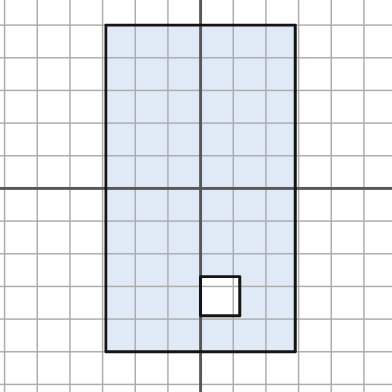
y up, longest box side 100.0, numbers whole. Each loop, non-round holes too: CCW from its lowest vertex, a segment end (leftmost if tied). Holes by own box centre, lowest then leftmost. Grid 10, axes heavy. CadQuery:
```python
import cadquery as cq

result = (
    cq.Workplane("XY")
    .moveTo(-29.0, -50.0)
    .lineTo(29.0, -50.0)
    .lineTo(29.0, 50.0)
    .lineTo(-29.0, 50.0)
    .close()
    .moveTo(0.0, -39.0)
    .lineTo(12.0, -39.0)
    .lineTo(12.0, -27.0)
    .lineTo(0.0, -27.0)
    .close()
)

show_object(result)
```